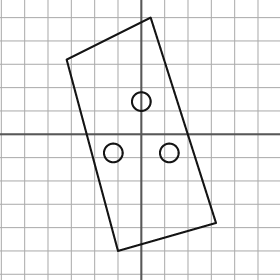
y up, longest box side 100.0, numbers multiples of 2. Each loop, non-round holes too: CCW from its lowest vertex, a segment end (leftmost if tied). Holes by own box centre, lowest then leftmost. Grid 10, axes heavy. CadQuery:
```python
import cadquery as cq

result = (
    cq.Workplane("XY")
    .moveTo(-10.0, -50.0)
    .lineTo(32.0, -38.0)
    .lineTo(4.0, 50.0)
    .lineTo(-32.0, 32.0)
    .close()
    .moveTo(-12.0, -8.0)
    .circle(4.0)
    .moveTo(12.0, -8.0)
    .circle(4.0)
    .moveTo(0.0, 14.0)
    .circle(4.0)
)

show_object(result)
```